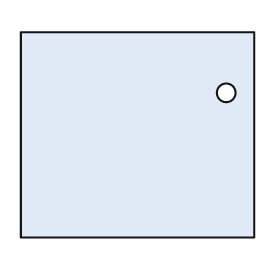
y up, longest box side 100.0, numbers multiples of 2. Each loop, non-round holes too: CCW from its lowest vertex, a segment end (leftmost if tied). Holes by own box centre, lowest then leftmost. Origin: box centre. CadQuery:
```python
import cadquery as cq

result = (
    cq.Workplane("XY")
    .moveTo(-50.0, -44.0)
    .lineTo(50.0, -44.0)
    .lineTo(50.0, 44.0)
    .lineTo(-50.0, 44.0)
    .close()
    .moveTo(38.0, 18.0)
    .circle(4.0)
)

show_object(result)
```